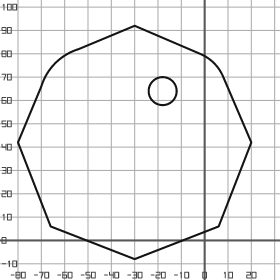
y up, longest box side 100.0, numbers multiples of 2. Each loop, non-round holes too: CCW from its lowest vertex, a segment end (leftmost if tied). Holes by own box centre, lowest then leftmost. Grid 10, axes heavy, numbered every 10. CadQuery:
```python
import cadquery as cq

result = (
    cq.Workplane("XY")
    .moveTo(-30.0, -8.0)
    .lineTo(6.0, 6.0)
    .lineTo(20.0, 42.0)
    .lineTo(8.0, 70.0)
    .threePointArc((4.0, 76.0), (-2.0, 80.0))
    .lineTo(-30.0, 92.0)
    .lineTo(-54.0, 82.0)
    .threePointArc((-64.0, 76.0), (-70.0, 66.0))
    .lineTo(-80.0, 42.0)
    .lineTo(-66.0, 6.0)
    .close()
    .moveTo(-18.0, 64.0)
    .circle(6.0)
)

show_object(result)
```